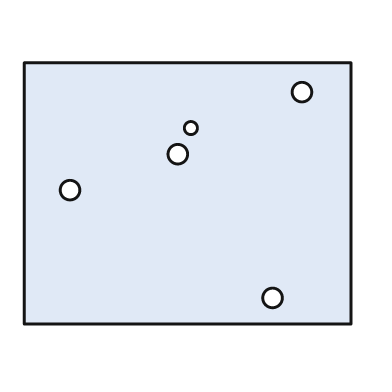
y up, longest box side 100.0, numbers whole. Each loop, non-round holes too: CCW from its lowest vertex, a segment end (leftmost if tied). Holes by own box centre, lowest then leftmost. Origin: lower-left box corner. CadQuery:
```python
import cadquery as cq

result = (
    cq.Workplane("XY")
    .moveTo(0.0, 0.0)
    .lineTo(100.0, 0.0)
    .lineTo(100.0, 80.0)
    .lineTo(0.0, 80.0)
    .close()
    .moveTo(76.0, 8.0)
    .circle(3.0)
    .moveTo(14.0, 41.0)
    .circle(3.0)
    .moveTo(47.0, 52.0)
    .circle(3.0)
    .moveTo(51.0, 60.0)
    .circle(2.0)
    .moveTo(85.0, 71.0)
    .circle(3.0)
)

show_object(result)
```